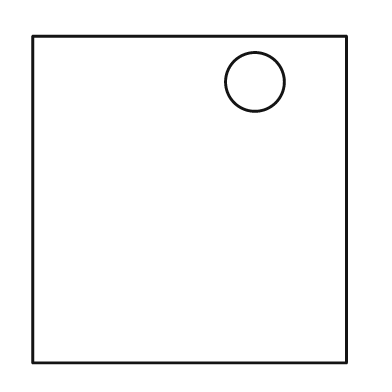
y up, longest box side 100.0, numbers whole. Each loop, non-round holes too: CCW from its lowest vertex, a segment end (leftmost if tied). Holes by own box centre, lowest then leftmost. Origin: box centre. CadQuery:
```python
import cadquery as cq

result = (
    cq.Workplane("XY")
    .moveTo(-48.0, -50.0)
    .lineTo(48.0, -50.0)
    .lineTo(48.0, 50.0)
    .lineTo(-48.0, 50.0)
    .close()
    .moveTo(20.0, 36.0)
    .circle(9.0)
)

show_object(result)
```